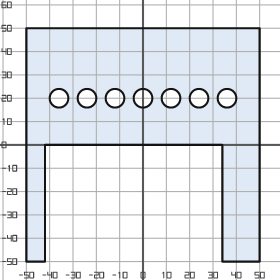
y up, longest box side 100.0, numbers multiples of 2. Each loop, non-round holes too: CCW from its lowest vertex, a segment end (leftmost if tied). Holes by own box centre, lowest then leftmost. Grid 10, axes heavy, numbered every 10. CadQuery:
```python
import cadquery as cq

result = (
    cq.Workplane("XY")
    .moveTo(-50.0, -50.0)
    .lineTo(-42.0, -50.0)
    .lineTo(-42.0, 0.0)
    .lineTo(34.0, 0.0)
    .lineTo(34.0, -50.0)
    .lineTo(50.0, -50.0)
    .lineTo(50.0, 50.0)
    .lineTo(-50.0, 50.0)
    .close()
    .moveTo(-36.0, 20.0)
    .circle(4.0)
    .moveTo(-24.0, 20.0)
    .circle(4.0)
    .moveTo(-12.0, 20.0)
    .circle(4.0)
    .moveTo(0.0, 20.0)
    .circle(4.0)
    .moveTo(12.0, 20.0)
    .circle(4.0)
    .moveTo(24.0, 20.0)
    .circle(4.0)
    .moveTo(36.0, 20.0)
    .circle(4.0)
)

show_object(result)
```